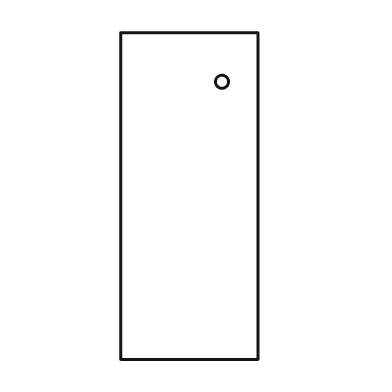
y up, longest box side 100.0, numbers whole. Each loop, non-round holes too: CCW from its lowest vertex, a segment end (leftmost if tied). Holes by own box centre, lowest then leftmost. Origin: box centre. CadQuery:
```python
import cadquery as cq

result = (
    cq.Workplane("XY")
    .moveTo(-21.0, -50.0)
    .lineTo(21.0, -50.0)
    .lineTo(21.0, 50.0)
    .lineTo(-21.0, 50.0)
    .close()
    .moveTo(10.0, 35.0)
    .circle(2.0)
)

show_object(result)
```